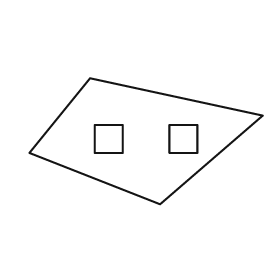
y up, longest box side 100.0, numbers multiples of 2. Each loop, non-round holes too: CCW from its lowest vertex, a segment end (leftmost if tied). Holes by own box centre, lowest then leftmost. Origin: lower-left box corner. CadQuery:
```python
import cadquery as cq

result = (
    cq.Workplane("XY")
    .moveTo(56.0, 0.0)
    .lineTo(100.0, 38.0)
    .lineTo(26.0, 54.0)
    .lineTo(0.0, 22.0)
    .close()
    .moveTo(28.0, 22.0)
    .lineTo(40.0, 22.0)
    .lineTo(40.0, 34.0)
    .lineTo(28.0, 34.0)
    .close()
    .moveTo(60.0, 22.0)
    .lineTo(72.0, 22.0)
    .lineTo(72.0, 34.0)
    .lineTo(60.0, 34.0)
    .close()
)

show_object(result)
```